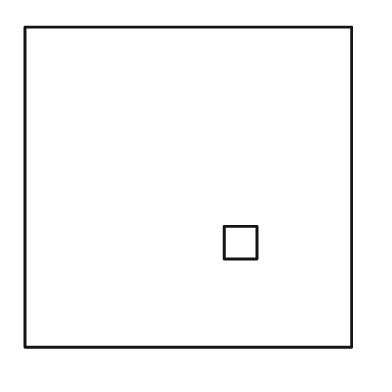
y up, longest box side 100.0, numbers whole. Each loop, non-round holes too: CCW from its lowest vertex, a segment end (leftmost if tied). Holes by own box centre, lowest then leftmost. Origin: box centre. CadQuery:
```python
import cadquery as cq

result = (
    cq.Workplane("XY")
    .moveTo(-50.0, -49.0)
    .lineTo(50.0, -49.0)
    .lineTo(50.0, 49.0)
    .lineTo(-50.0, 49.0)
    .close()
    .moveTo(11.0, -22.0)
    .lineTo(21.0, -22.0)
    .lineTo(21.0, -12.0)
    .lineTo(11.0, -12.0)
    .close()
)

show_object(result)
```